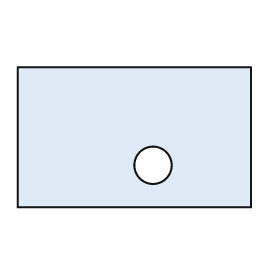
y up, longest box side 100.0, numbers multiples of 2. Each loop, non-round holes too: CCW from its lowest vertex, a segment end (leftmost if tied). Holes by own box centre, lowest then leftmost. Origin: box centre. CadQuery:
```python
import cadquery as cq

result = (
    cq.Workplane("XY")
    .moveTo(-50.0, -30.0)
    .lineTo(50.0, -30.0)
    .lineTo(50.0, 30.0)
    .lineTo(-50.0, 30.0)
    .close()
    .moveTo(8.0, -12.0)
    .circle(8.0)
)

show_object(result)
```